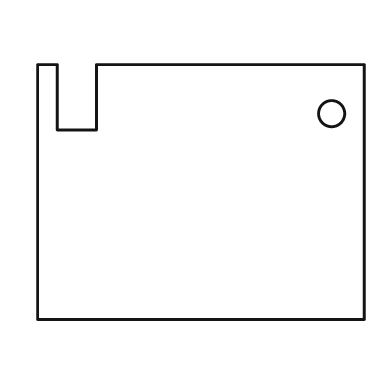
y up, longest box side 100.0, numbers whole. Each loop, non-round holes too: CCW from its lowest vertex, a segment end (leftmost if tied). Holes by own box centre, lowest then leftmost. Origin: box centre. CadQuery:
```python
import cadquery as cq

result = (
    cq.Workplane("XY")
    .moveTo(-50.0, -39.0)
    .lineTo(50.0, -39.0)
    .lineTo(50.0, 39.0)
    .lineTo(-32.0, 39.0)
    .lineTo(-32.0, 19.0)
    .lineTo(-44.0, 19.0)
    .lineTo(-44.0, 39.0)
    .lineTo(-50.0, 39.0)
    .close()
    .moveTo(40.0, 24.0)
    .circle(4.0)
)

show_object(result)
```